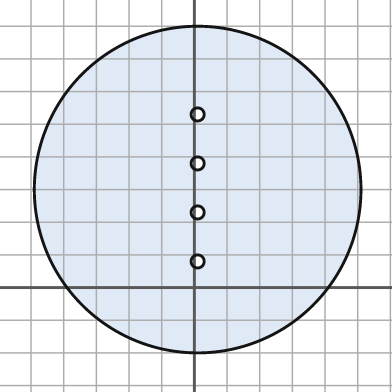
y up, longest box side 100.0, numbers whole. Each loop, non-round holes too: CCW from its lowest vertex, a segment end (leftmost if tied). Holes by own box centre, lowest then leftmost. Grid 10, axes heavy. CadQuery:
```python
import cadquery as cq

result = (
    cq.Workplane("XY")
    .moveTo(1.0, 30.0)
    .circle(50.0)
    .moveTo(1.0, 8.0)
    .circle(2.0)
    .moveTo(1.0, 23.0)
    .circle(2.0)
    .moveTo(1.0, 38.0)
    .circle(2.0)
    .moveTo(1.0, 53.0)
    .circle(2.0)
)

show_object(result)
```